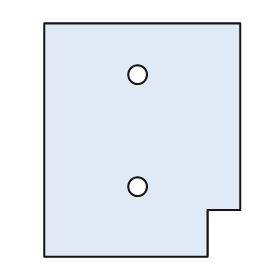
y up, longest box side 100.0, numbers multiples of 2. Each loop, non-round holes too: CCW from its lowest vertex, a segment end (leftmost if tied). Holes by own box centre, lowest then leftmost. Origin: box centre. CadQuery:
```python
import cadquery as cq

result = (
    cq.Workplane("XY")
    .moveTo(-42.0, -50.0)
    .lineTo(28.0, -50.0)
    .lineTo(28.0, -30.0)
    .lineTo(42.0, -30.0)
    .lineTo(42.0, 50.0)
    .lineTo(-42.0, 50.0)
    .close()
    .moveTo(-2.0, -20.0)
    .circle(4.0)
    .moveTo(-2.0, 28.0)
    .circle(4.0)
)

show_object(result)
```